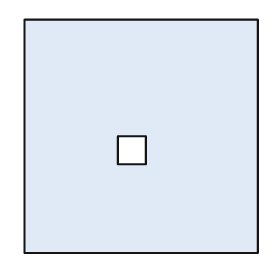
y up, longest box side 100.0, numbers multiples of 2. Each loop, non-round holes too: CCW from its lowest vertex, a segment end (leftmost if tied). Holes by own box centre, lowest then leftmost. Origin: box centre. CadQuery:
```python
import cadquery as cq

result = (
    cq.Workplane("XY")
    .moveTo(-50.0, -50.0)
    .lineTo(50.0, -50.0)
    .lineTo(50.0, 50.0)
    .lineTo(-50.0, 50.0)
    .close()
    .moveTo(-10.0, -12.0)
    .lineTo(2.0, -12.0)
    .lineTo(2.0, 0.0)
    .lineTo(-10.0, 0.0)
    .close()
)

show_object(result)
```